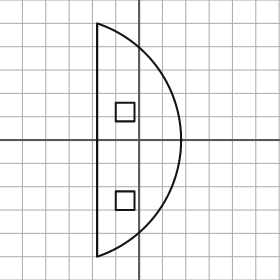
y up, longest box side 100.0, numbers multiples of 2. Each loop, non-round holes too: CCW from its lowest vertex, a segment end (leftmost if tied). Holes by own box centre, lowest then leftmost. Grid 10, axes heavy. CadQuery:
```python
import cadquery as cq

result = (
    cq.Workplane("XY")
    .moveTo(-18.0, -50.0)
    .threePointArc((18.0, 0.0), (-18.0, 50.0))
    .close()
    .moveTo(-10.0, -30.0)
    .lineTo(-2.0, -30.0)
    .lineTo(-2.0, -22.0)
    .lineTo(-10.0, -22.0)
    .close()
    .moveTo(-10.0, 8.0)
    .lineTo(-2.0, 8.0)
    .lineTo(-2.0, 16.0)
    .lineTo(-10.0, 16.0)
    .close()
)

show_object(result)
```